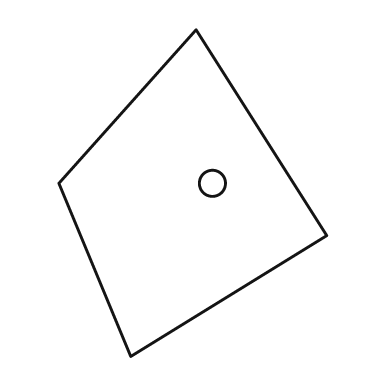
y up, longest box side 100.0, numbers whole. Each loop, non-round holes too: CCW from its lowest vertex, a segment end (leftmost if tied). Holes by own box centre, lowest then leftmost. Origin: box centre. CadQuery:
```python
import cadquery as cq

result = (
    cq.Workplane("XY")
    .moveTo(-19.0, -50.0)
    .lineTo(41.0, -13.0)
    .lineTo(1.0, 50.0)
    .lineTo(-41.0, 3.0)
    .close()
    .moveTo(6.0, 3.0)
    .circle(4.0)
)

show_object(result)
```